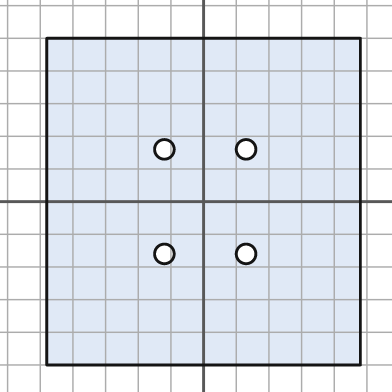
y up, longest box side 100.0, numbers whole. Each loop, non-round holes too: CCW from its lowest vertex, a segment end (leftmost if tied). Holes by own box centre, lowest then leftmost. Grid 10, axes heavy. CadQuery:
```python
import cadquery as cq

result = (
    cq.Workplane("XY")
    .moveTo(-48.0, -50.0)
    .lineTo(48.0, -50.0)
    .lineTo(48.0, 50.0)
    .lineTo(-48.0, 50.0)
    .close()
    .moveTo(-12.0, -16.0)
    .circle(3.0)
    .moveTo(13.0, -16.0)
    .circle(3.0)
    .moveTo(-12.0, 16.0)
    .circle(3.0)
    .moveTo(13.0, 16.0)
    .circle(3.0)
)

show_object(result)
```